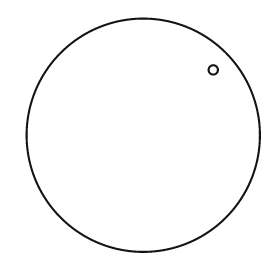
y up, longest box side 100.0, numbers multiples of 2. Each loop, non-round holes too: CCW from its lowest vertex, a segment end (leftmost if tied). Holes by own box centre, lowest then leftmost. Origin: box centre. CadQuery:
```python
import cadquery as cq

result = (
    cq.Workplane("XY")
    .moveTo(0.0, 0.0)
    .circle(50.0)
    .moveTo(30.0, 28.0)
    .circle(2.0)
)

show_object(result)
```